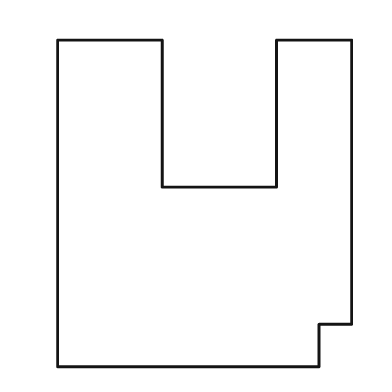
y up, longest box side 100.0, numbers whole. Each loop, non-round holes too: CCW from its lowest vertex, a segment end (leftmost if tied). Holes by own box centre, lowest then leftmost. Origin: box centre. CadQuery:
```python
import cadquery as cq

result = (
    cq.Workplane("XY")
    .moveTo(-45.0, -50.0)
    .lineTo(35.0, -50.0)
    .lineTo(35.0, -37.0)
    .lineTo(45.0, -37.0)
    .lineTo(45.0, 50.0)
    .lineTo(22.0, 50.0)
    .lineTo(22.0, 5.0)
    .lineTo(-13.0, 5.0)
    .lineTo(-13.0, 50.0)
    .lineTo(-45.0, 50.0)
    .close()
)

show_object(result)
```